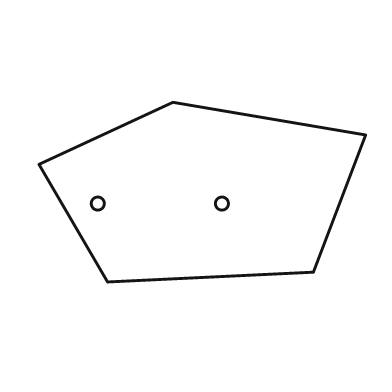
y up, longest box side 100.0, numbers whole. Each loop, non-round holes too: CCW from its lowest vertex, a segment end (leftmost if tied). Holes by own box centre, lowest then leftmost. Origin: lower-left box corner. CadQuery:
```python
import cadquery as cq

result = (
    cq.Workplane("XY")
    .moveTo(21.0, 0.0)
    .lineTo(84.0, 3.0)
    .lineTo(100.0, 45.0)
    .lineTo(41.0, 55.0)
    .lineTo(0.0, 36.0)
    .close()
    .moveTo(18.0, 24.0)
    .circle(2.0)
    .moveTo(56.0, 24.0)
    .circle(2.0)
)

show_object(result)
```